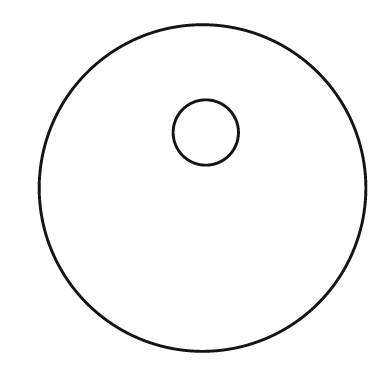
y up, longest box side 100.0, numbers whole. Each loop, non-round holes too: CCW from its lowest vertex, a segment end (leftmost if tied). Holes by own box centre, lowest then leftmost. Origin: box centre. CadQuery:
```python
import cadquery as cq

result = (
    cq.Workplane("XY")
    .moveTo(0.0, 0.0)
    .circle(50.0)
    .moveTo(1.0, 17.0)
    .circle(10.0)
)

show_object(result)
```